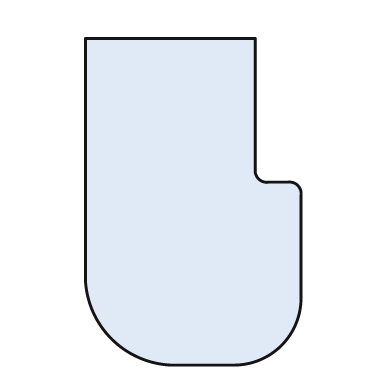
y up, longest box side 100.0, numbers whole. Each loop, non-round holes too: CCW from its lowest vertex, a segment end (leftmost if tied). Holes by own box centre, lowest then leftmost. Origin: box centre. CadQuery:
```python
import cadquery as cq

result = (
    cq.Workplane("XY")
    .moveTo(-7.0, -50.0)
    .lineTo(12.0, -50.0)
    .threePointArc((27.0, -44.0), (33.0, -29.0))
    .lineTo(33.0, 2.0)
    .threePointArc((32.0, 5.0), (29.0, 6.0))
    .lineTo(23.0, 6.0)
    .threePointArc((20.0, 7.0), (19.0, 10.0))
    .lineTo(19.0, 50.0)
    .lineTo(-33.0, 50.0)
    .lineTo(-33.0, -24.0)
    .threePointArc((-25.0, -42.0), (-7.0, -50.0))
    .close()
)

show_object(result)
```